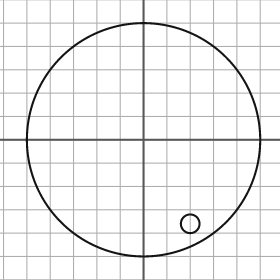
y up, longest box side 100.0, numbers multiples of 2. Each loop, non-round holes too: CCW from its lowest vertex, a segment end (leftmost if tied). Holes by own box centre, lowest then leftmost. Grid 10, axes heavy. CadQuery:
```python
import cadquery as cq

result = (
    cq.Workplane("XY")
    .moveTo(0.0, 0.0)
    .circle(50.0)
    .moveTo(20.0, -36.0)
    .circle(4.0)
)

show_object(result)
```